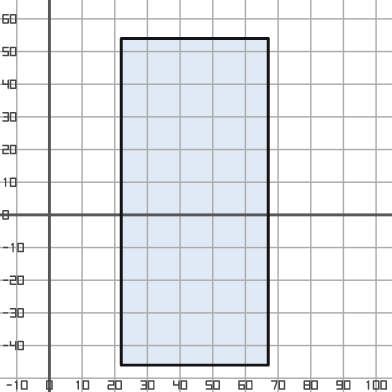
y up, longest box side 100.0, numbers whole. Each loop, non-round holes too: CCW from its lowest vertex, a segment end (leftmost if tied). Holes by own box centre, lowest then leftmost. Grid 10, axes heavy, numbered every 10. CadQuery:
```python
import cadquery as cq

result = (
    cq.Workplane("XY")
    .moveTo(22.0, -46.0)
    .lineTo(67.0, -46.0)
    .lineTo(67.0, 54.0)
    .lineTo(22.0, 54.0)
    .close()
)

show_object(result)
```